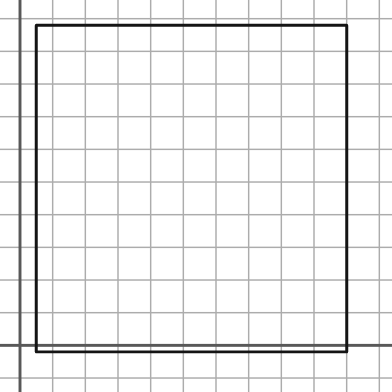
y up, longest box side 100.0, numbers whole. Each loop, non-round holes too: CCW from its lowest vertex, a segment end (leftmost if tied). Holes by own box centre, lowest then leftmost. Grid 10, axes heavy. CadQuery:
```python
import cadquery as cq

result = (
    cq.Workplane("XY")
    .moveTo(5.0, -2.0)
    .lineTo(100.0, -2.0)
    .lineTo(100.0, 98.0)
    .lineTo(5.0, 98.0)
    .close()
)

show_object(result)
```